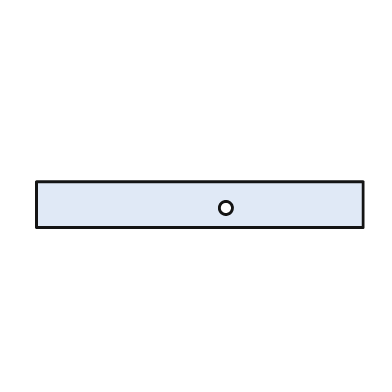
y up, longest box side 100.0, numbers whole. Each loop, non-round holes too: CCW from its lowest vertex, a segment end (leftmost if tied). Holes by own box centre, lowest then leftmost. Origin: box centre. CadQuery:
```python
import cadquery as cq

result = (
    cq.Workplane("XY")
    .moveTo(-50.0, -7.0)
    .lineTo(50.0, -7.0)
    .lineTo(50.0, 7.0)
    .lineTo(-50.0, 7.0)
    .close()
    .moveTo(8.0, -1.0)
    .circle(2.0)
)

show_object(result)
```